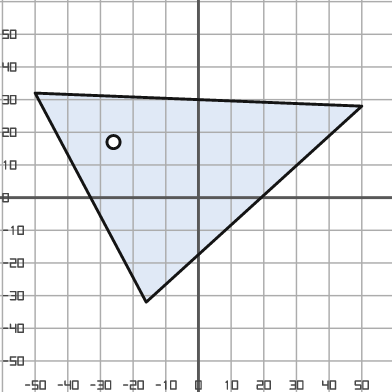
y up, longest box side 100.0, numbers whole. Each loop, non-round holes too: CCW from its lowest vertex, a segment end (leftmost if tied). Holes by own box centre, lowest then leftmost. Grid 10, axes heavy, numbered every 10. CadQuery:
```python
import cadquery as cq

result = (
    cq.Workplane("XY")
    .moveTo(-16.0, -32.0)
    .lineTo(50.0, 28.0)
    .lineTo(-50.0, 32.0)
    .close()
    .moveTo(-26.0, 17.0)
    .circle(2.0)
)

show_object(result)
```